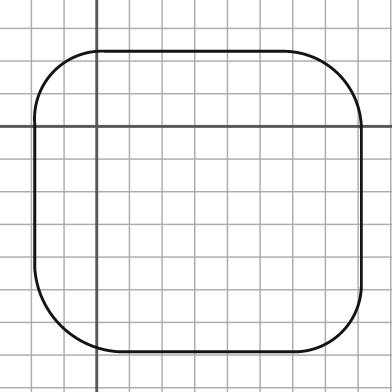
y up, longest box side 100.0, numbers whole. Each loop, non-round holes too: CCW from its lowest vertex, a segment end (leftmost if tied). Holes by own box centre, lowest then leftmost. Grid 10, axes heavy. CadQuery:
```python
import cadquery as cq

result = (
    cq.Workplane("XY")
    .moveTo(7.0, -69.0)
    .lineTo(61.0, -69.0)
    .threePointArc((75.0, -63.0), (81.0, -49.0))
    .lineTo(81.0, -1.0)
    .threePointArc((74.0, 16.0), (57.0, 23.0))
    .lineTo(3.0, 23.0)
    .threePointArc((-13.0, 17.0), (-19.0, 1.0))
    .lineTo(-19.0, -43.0)
    .threePointArc((-11.0, -61.0), (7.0, -69.0))
    .close()
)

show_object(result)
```